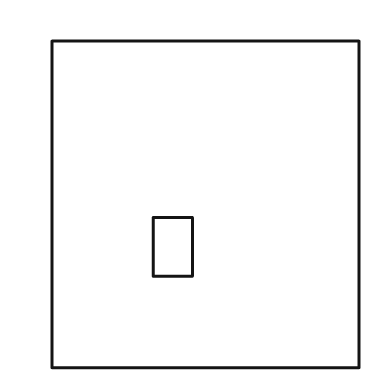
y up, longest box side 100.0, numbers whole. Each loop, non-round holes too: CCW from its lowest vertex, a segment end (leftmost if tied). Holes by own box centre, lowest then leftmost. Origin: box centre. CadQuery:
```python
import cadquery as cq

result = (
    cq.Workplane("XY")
    .moveTo(-47.0, -50.0)
    .lineTo(47.0, -50.0)
    .lineTo(47.0, 50.0)
    .lineTo(-47.0, 50.0)
    .close()
    .moveTo(-16.0, -22.0)
    .lineTo(-4.0, -22.0)
    .lineTo(-4.0, -4.0)
    .lineTo(-16.0, -4.0)
    .close()
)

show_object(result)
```